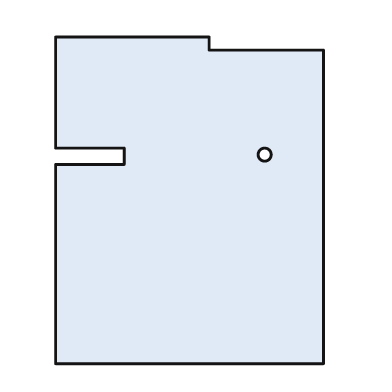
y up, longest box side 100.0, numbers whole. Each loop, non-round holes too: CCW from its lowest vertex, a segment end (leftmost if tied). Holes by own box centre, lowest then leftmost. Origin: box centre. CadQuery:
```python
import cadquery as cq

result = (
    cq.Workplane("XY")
    .moveTo(-41.0, -50.0)
    .lineTo(41.0, -50.0)
    .lineTo(41.0, 46.0)
    .lineTo(6.0, 46.0)
    .lineTo(6.0, 50.0)
    .lineTo(-41.0, 50.0)
    .lineTo(-41.0, 16.0)
    .lineTo(-20.0, 16.0)
    .lineTo(-20.0, 11.0)
    .lineTo(-41.0, 11.0)
    .close()
    .moveTo(23.0, 14.0)
    .circle(2.0)
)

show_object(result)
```